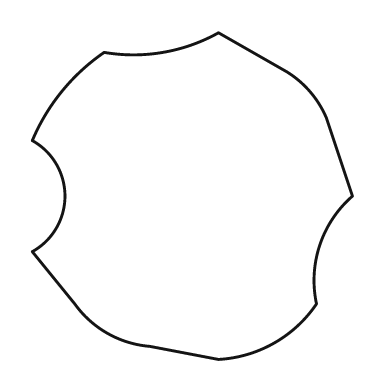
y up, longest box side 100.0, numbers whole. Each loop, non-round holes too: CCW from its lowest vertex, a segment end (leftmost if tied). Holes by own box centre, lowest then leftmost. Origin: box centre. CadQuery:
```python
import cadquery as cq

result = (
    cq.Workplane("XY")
    .moveTo(8.0, -50.0)
    .threePointArc((25.0, -45.0), (38.0, -33.0))
    .threePointArc((39.0, -15.0), (49.0, 0.0))
    .lineTo(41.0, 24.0)
    .threePointArc((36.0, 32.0), (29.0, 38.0))
    .lineTo(8.0, 50.0)
    .threePointArc((-9.0, 44.0), (-27.0, 44.0))
    .threePointArc((-40.0, 32.0), (-49.0, 17.0))
    .threePointArc((-39.0, 0.0), (-49.0, -17.0))
    .lineTo(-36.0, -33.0)
    .threePointArc((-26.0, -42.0), (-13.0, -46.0))
    .close()
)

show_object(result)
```